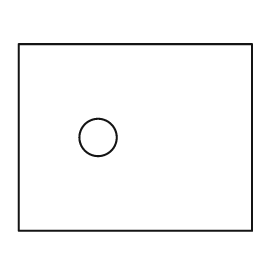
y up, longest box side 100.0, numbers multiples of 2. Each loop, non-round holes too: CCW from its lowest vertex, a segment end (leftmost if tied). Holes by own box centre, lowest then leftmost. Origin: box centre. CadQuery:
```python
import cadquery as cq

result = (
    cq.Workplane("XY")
    .moveTo(-50.0, -40.0)
    .lineTo(50.0, -40.0)
    .lineTo(50.0, 40.0)
    .lineTo(-50.0, 40.0)
    .close()
    .moveTo(-16.0, 0.0)
    .circle(8.0)
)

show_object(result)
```